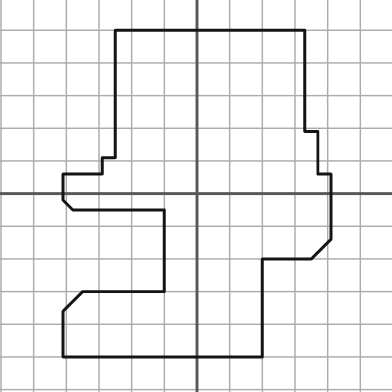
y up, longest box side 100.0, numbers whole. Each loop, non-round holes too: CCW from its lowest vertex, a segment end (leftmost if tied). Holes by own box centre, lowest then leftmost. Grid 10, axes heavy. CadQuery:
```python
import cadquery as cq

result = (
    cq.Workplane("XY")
    .moveTo(-41.0, -50.0)
    .lineTo(20.0, -50.0)
    .lineTo(20.0, -20.0)
    .lineTo(35.0, -20.0)
    .lineTo(41.0, -14.0)
    .lineTo(41.0, 6.0)
    .lineTo(37.0, 6.0)
    .lineTo(37.0, 19.0)
    .lineTo(33.0, 19.0)
    .lineTo(33.0, 50.0)
    .lineTo(-25.0, 50.0)
    .lineTo(-25.0, 11.0)
    .lineTo(-29.0, 11.0)
    .lineTo(-29.0, 6.0)
    .lineTo(-41.0, 6.0)
    .lineTo(-41.0, -2.0)
    .lineTo(-38.0, -5.0)
    .lineTo(-10.0, -5.0)
    .lineTo(-10.0, -30.0)
    .lineTo(-35.0, -30.0)
    .lineTo(-41.0, -36.0)
    .close()
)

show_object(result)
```